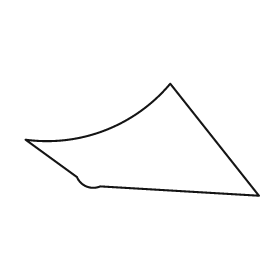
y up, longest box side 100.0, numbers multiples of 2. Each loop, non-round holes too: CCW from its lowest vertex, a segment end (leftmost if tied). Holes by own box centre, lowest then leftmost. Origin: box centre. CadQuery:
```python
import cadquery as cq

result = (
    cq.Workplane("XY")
    .moveTo(50.0, -24.0)
    .lineTo(12.0, 24.0)
    .threePointArc((-16.0, 4.0), (-50.0, 0.0))
    .lineTo(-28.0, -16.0)
    .threePointArc((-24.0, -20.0), (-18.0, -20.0))
    .close()
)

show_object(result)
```